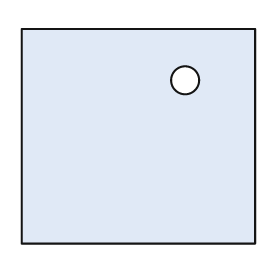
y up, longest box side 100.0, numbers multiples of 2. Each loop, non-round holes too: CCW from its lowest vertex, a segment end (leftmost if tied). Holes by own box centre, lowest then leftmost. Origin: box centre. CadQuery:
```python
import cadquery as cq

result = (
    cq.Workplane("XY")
    .moveTo(-50.0, -46.0)
    .lineTo(50.0, -46.0)
    .lineTo(50.0, 46.0)
    .lineTo(-50.0, 46.0)
    .close()
    .moveTo(20.0, 24.0)
    .circle(6.0)
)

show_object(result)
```